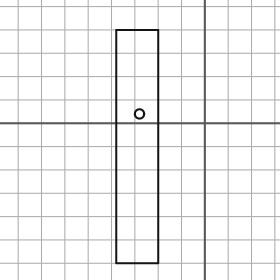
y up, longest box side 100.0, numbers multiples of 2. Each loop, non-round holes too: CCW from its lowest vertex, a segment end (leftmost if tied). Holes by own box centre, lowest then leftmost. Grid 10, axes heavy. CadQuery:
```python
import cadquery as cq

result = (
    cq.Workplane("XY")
    .moveTo(-38.0, -60.0)
    .lineTo(-20.0, -60.0)
    .lineTo(-20.0, 40.0)
    .lineTo(-38.0, 40.0)
    .close()
    .moveTo(-28.0, 4.0)
    .circle(2.0)
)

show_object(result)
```